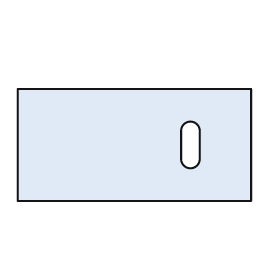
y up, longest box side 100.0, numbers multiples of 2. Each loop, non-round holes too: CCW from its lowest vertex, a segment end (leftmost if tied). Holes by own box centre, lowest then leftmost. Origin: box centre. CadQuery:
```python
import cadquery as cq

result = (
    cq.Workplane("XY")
    .moveTo(-50.0, -24.0)
    .lineTo(50.0, -24.0)
    .lineTo(50.0, 24.0)
    .lineTo(-50.0, 24.0)
    .close()
    .moveTo(20.0, -6.0)
    .threePointArc((24.0, -10.0), (28.0, -6.0))
    .lineTo(28.0, 6.0)
    .threePointArc((24.0, 10.0), (20.0, 6.0))
    .close()
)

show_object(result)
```